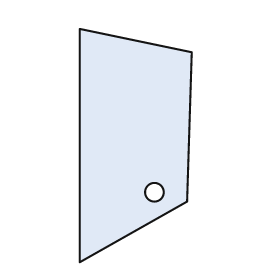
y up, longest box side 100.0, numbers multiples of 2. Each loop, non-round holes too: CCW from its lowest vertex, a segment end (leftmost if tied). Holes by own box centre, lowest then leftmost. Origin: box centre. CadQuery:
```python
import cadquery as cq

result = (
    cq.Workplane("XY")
    .moveTo(-24.0, -50.0)
    .lineTo(22.0, -24.0)
    .lineTo(24.0, 40.0)
    .lineTo(-24.0, 50.0)
    .close()
    .moveTo(8.0, -20.0)
    .circle(4.0)
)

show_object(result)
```